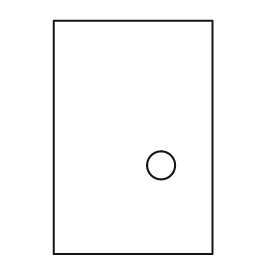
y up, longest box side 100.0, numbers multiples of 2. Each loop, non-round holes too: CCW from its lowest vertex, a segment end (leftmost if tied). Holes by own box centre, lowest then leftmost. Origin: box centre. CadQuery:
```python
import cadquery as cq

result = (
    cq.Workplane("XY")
    .moveTo(-34.0, -50.0)
    .lineTo(34.0, -50.0)
    .lineTo(34.0, 50.0)
    .lineTo(-34.0, 50.0)
    .close()
    .moveTo(12.0, -12.0)
    .circle(6.0)
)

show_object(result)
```